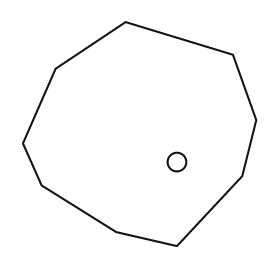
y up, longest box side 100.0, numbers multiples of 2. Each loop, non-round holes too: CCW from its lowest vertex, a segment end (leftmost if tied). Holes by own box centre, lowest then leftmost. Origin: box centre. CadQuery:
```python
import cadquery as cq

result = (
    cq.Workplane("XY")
    .moveTo(16.0, -48.0)
    .lineTo(44.0, -18.0)
    .lineTo(50.0, 6.0)
    .lineTo(40.0, 34.0)
    .lineTo(-6.0, 48.0)
    .lineTo(-36.0, 28.0)
    .lineTo(-50.0, -4.0)
    .lineTo(-42.0, -22.0)
    .lineTo(-10.0, -42.0)
    .close()
    .moveTo(16.0, -12.0)
    .circle(4.0)
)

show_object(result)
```